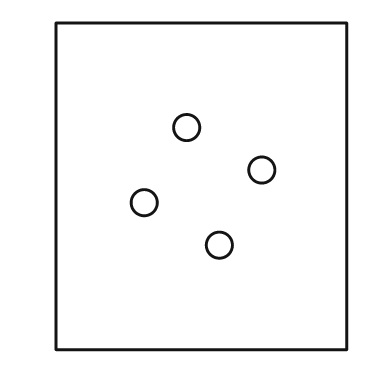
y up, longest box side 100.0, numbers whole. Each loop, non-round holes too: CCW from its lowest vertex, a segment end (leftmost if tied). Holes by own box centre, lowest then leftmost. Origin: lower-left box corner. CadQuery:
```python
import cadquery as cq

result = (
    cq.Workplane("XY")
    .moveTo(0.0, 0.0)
    .lineTo(89.0, 0.0)
    .lineTo(89.0, 100.0)
    .lineTo(0.0, 100.0)
    .close()
    .moveTo(50.0, 32.0)
    .circle(4.0)
    .moveTo(27.0, 45.0)
    .circle(4.0)
    .moveTo(63.0, 55.0)
    .circle(4.0)
    .moveTo(40.0, 68.0)
    .circle(4.0)
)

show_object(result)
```